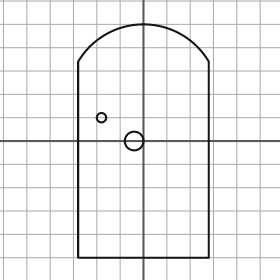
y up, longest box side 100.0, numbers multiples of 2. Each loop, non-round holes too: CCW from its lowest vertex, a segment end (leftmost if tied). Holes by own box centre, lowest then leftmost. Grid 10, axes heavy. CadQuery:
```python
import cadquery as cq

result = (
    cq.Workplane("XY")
    .moveTo(-28.0, -50.0)
    .lineTo(28.0, -50.0)
    .lineTo(28.0, 34.0)
    .threePointArc((0.0, 50.0), (-28.0, 34.0))
    .close()
    .moveTo(-4.0, 0.0)
    .circle(4.0)
    .moveTo(-18.0, 10.0)
    .circle(2.0)
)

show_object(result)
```